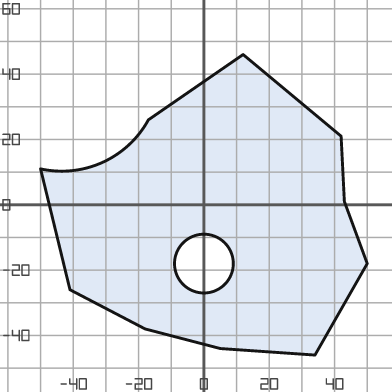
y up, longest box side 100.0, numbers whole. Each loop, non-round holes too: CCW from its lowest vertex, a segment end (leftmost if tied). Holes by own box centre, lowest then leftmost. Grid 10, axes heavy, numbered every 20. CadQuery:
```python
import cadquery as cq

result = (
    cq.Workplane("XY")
    .moveTo(34.0, -46.0)
    .lineTo(50.0, -18.0)
    .lineTo(43.0, 1.0)
    .lineTo(42.0, 21.0)
    .lineTo(12.0, 46.0)
    .lineTo(-17.0, 26.0)
    .threePointArc((-31.0, 13.0), (-50.0, 11.0))
    .lineTo(-41.0, -26.0)
    .lineTo(-18.0, -38.0)
    .lineTo(5.0, -44.0)
    .close()
    .moveTo(0.0, -18.0)
    .circle(9.0)
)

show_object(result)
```